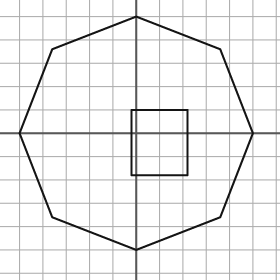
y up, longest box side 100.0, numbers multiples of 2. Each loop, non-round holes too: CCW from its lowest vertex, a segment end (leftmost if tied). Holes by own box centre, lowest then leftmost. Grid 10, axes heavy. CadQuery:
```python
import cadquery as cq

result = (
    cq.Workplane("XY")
    .moveTo(0.0, -50.0)
    .lineTo(36.0, -36.0)
    .lineTo(50.0, 0.0)
    .lineTo(36.0, 36.0)
    .lineTo(0.0, 50.0)
    .lineTo(-36.0, 36.0)
    .lineTo(-50.0, 0.0)
    .lineTo(-36.0, -36.0)
    .close()
    .moveTo(-2.0, -18.0)
    .lineTo(22.0, -18.0)
    .lineTo(22.0, 10.0)
    .lineTo(-2.0, 10.0)
    .close()
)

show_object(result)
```